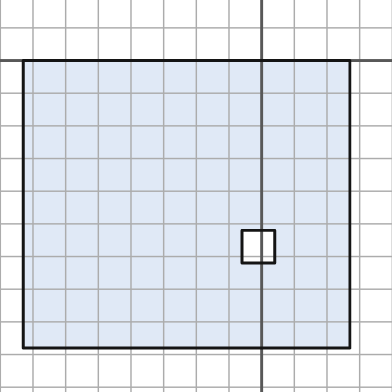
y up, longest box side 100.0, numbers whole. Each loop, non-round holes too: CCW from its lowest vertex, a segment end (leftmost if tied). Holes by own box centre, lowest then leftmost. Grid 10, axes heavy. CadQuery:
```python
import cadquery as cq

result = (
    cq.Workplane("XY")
    .moveTo(-73.0, -88.0)
    .lineTo(27.0, -88.0)
    .lineTo(27.0, 0.0)
    .lineTo(-73.0, 0.0)
    .close()
    .moveTo(-6.0, -62.0)
    .lineTo(4.0, -62.0)
    .lineTo(4.0, -52.0)
    .lineTo(-6.0, -52.0)
    .close()
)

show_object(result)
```